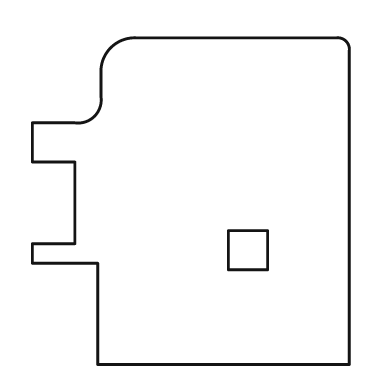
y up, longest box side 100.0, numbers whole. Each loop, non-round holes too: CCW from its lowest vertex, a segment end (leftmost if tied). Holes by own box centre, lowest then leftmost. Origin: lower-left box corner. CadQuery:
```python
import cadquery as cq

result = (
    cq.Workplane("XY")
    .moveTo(20.0, 0.0)
    .lineTo(97.0, 0.0)
    .lineTo(97.0, 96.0)
    .threePointArc((96.0, 99.0), (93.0, 100.0))
    .lineTo(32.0, 100.0)
    .threePointArc((24.0, 97.0), (21.0, 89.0))
    .lineTo(21.0, 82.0)
    .threePointArc((19.0, 76.0), (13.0, 74.0))
    .lineTo(0.0, 74.0)
    .lineTo(0.0, 62.0)
    .lineTo(13.0, 62.0)
    .lineTo(13.0, 37.0)
    .lineTo(0.0, 37.0)
    .lineTo(0.0, 31.0)
    .lineTo(20.0, 31.0)
    .close()
    .moveTo(60.0, 29.0)
    .lineTo(72.0, 29.0)
    .lineTo(72.0, 41.0)
    .lineTo(60.0, 41.0)
    .close()
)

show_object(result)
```